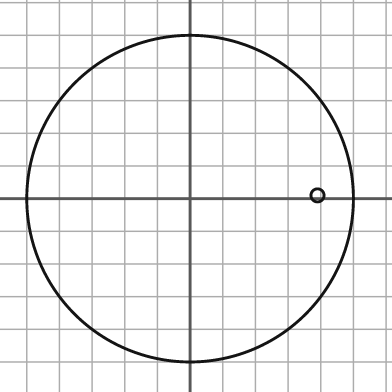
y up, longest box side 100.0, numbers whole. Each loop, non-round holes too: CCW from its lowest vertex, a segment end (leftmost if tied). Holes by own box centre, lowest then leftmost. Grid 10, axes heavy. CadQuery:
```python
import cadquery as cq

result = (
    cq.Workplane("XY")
    .moveTo(0.0, 0.0)
    .circle(50.0)
    .moveTo(39.0, 1.0)
    .circle(2.0)
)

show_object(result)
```